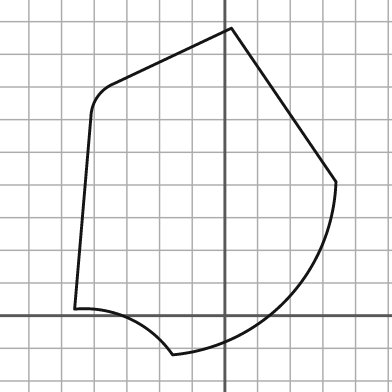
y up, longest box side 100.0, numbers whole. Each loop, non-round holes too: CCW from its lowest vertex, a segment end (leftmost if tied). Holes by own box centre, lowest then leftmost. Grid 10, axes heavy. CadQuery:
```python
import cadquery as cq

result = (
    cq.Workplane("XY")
    .moveTo(-16.0, -12.0)
    .threePointArc((19.0, 5.0), (34.0, 41.0))
    .lineTo(2.0, 88.0)
    .lineTo(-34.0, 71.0)
    .threePointArc((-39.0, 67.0), (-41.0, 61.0))
    .lineTo(-46.0, 2.0)
    .threePointArc((-29.0, -1.0), (-16.0, -12.0))
    .close()
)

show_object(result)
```